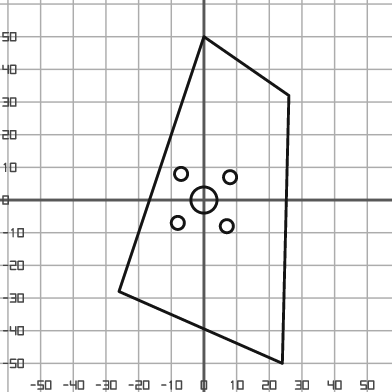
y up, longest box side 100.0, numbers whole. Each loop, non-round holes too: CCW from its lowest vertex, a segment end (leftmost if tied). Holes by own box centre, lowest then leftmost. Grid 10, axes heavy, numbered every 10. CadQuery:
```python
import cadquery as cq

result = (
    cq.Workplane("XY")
    .moveTo(24.0, -50.0)
    .lineTo(26.0, 32.0)
    .lineTo(0.0, 50.0)
    .lineTo(-26.0, -28.0)
    .close()
    .moveTo(7.0, -8.0)
    .circle(2.0)
    .moveTo(-8.0, -7.0)
    .circle(2.0)
    .moveTo(0.0, 0.0)
    .circle(4.0)
    .moveTo(8.0, 7.0)
    .circle(2.0)
    .moveTo(-7.0, 8.0)
    .circle(2.0)
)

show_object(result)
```